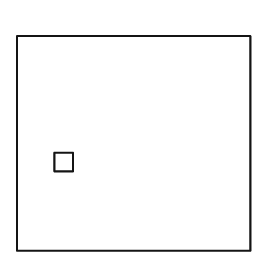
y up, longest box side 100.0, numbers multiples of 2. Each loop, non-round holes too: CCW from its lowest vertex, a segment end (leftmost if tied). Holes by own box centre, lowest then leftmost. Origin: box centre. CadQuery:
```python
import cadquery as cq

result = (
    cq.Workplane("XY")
    .moveTo(-50.0, -46.0)
    .lineTo(50.0, -46.0)
    .lineTo(50.0, 46.0)
    .lineTo(-50.0, 46.0)
    .close()
    .moveTo(-34.0, -12.0)
    .lineTo(-26.0, -12.0)
    .lineTo(-26.0, -4.0)
    .lineTo(-34.0, -4.0)
    .close()
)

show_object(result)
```